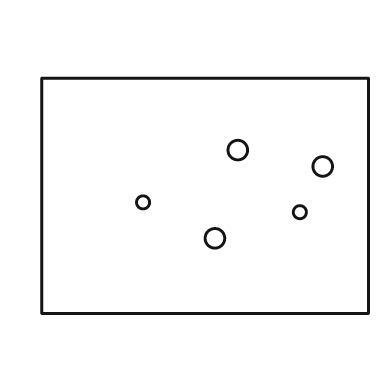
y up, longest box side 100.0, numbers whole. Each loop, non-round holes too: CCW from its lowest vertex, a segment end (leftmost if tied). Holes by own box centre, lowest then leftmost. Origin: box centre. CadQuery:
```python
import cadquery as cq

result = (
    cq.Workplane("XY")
    .moveTo(-50.0, -36.0)
    .lineTo(50.0, -36.0)
    .lineTo(50.0, 36.0)
    .lineTo(-50.0, 36.0)
    .close()
    .moveTo(3.0, -13.0)
    .circle(3.0)
    .moveTo(29.0, -5.0)
    .circle(2.0)
    .moveTo(-19.0, -2.0)
    .circle(2.0)
    .moveTo(36.0, 9.0)
    .circle(3.0)
    .moveTo(10.0, 14.0)
    .circle(3.0)
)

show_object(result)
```